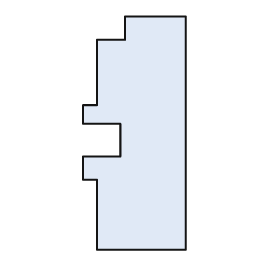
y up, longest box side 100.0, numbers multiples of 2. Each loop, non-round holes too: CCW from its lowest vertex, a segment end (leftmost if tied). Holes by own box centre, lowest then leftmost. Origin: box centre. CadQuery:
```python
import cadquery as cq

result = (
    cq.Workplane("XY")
    .moveTo(-16.0, -50.0)
    .lineTo(22.0, -50.0)
    .lineTo(22.0, 50.0)
    .lineTo(-4.0, 50.0)
    .lineTo(-4.0, 40.0)
    .lineTo(-16.0, 40.0)
    .lineTo(-16.0, 12.0)
    .lineTo(-22.0, 12.0)
    .lineTo(-22.0, 4.0)
    .lineTo(-6.0, 4.0)
    .lineTo(-6.0, -10.0)
    .lineTo(-22.0, -10.0)
    .lineTo(-22.0, -20.0)
    .lineTo(-16.0, -20.0)
    .close()
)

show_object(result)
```